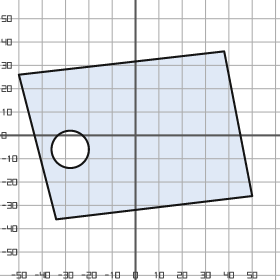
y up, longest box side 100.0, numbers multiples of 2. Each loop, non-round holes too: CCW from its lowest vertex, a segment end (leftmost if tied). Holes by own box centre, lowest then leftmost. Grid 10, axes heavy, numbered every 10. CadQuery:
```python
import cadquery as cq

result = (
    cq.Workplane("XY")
    .moveTo(-34.0, -36.0)
    .lineTo(50.0, -26.0)
    .lineTo(38.0, 36.0)
    .lineTo(-50.0, 26.0)
    .close()
    .moveTo(-28.0, -6.0)
    .circle(8.0)
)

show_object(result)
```